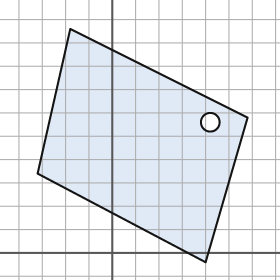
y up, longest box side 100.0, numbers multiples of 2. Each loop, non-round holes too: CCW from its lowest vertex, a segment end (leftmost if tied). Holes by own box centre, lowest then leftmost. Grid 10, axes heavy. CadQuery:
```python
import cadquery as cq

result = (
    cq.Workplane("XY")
    .moveTo(40.0, -4.0)
    .lineTo(58.0, 58.0)
    .lineTo(-18.0, 96.0)
    .lineTo(-32.0, 34.0)
    .close()
    .moveTo(42.0, 56.0)
    .circle(4.0)
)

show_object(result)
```